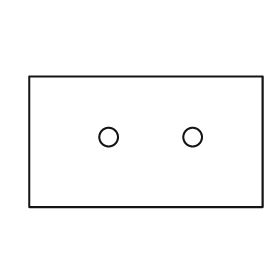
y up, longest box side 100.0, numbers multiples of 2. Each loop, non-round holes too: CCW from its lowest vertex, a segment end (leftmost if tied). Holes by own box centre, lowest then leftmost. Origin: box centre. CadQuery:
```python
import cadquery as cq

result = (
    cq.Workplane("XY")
    .moveTo(-50.0, -28.0)
    .lineTo(50.0, -28.0)
    .lineTo(50.0, 28.0)
    .lineTo(-50.0, 28.0)
    .close()
    .moveTo(-16.0, 2.0)
    .circle(4.0)
    .moveTo(20.0, 2.0)
    .circle(4.0)
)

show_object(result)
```